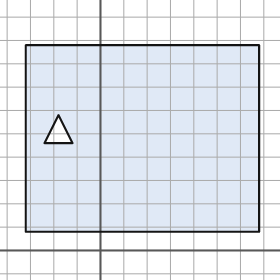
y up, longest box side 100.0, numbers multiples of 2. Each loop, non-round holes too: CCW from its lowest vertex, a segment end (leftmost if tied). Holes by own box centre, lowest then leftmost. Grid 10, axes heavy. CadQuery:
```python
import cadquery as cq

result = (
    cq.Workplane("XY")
    .moveTo(-32.0, 8.0)
    .lineTo(68.0, 8.0)
    .lineTo(68.0, 88.0)
    .lineTo(-32.0, 88.0)
    .close()
    .moveTo(-24.0, 46.0)
    .lineTo(-12.0, 46.0)
    .lineTo(-18.0, 58.0)
    .close()
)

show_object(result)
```